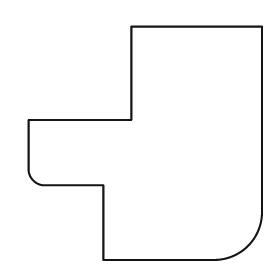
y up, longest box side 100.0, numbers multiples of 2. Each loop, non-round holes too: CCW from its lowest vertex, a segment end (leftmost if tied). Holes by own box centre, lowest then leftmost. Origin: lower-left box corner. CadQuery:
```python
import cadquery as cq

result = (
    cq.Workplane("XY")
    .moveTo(32.0, 0.0)
    .lineTo(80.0, 0.0)
    .threePointArc((94.0, 6.0), (100.0, 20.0))
    .lineTo(100.0, 100.0)
    .lineTo(44.0, 100.0)
    .lineTo(44.0, 60.0)
    .lineTo(0.0, 60.0)
    .lineTo(0.0, 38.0)
    .threePointArc((2.0, 34.0), (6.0, 32.0))
    .lineTo(32.0, 32.0)
    .close()
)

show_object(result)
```